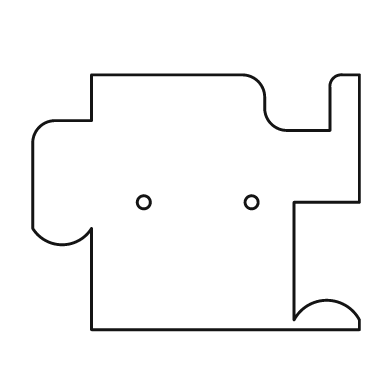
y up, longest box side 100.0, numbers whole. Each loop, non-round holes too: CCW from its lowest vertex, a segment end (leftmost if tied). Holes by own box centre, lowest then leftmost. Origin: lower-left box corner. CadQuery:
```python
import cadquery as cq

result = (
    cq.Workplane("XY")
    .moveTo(18.0, 0.0)
    .lineTo(100.0, 0.0)
    .lineTo(100.0, 3.0)
    .threePointArc((90.0, 9.0), (80.0, 3.0))
    .lineTo(80.0, 39.0)
    .lineTo(100.0, 39.0)
    .lineTo(100.0, 78.0)
    .lineTo(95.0, 78.0)
    .threePointArc((92.0, 77.0), (91.0, 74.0))
    .lineTo(91.0, 61.0)
    .lineTo(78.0, 61.0)
    .threePointArc((73.0, 63.0), (71.0, 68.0))
    .lineTo(71.0, 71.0)
    .threePointArc((69.0, 76.0), (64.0, 78.0))
    .lineTo(18.0, 78.0)
    .lineTo(18.0, 64.0)
    .lineTo(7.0, 64.0)
    .threePointArc((2.0, 62.0), (0.0, 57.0))
    .lineTo(0.0, 31.0)
    .threePointArc((9.0, 26.0), (18.0, 31.0))
    .close()
    .moveTo(34.0, 39.0)
    .circle(2.0)
    .moveTo(67.0, 39.0)
    .circle(2.0)
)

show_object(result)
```